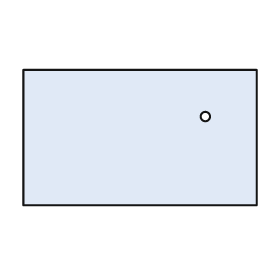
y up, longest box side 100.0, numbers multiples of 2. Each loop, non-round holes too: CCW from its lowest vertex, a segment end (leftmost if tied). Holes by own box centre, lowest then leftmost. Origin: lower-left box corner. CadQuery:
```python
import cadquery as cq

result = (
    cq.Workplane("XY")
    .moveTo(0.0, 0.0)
    .lineTo(100.0, 0.0)
    .lineTo(100.0, 58.0)
    .lineTo(0.0, 58.0)
    .close()
    .moveTo(78.0, 38.0)
    .circle(2.0)
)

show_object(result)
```